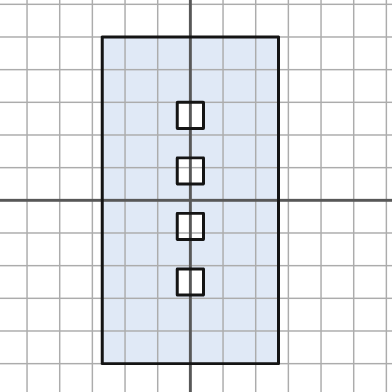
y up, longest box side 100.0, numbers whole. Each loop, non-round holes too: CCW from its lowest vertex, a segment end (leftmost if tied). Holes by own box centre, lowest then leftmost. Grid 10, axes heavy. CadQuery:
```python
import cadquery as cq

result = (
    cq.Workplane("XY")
    .moveTo(-27.0, -50.0)
    .lineTo(27.0, -50.0)
    .lineTo(27.0, 50.0)
    .lineTo(-27.0, 50.0)
    .close()
    .moveTo(-4.0, -29.0)
    .lineTo(4.0, -29.0)
    .lineTo(4.0, -21.0)
    .lineTo(-4.0, -21.0)
    .close()
    .moveTo(-4.0, -12.0)
    .lineTo(4.0, -12.0)
    .lineTo(4.0, -4.0)
    .lineTo(-4.0, -4.0)
    .close()
    .moveTo(-4.0, 5.0)
    .lineTo(4.0, 5.0)
    .lineTo(4.0, 13.0)
    .lineTo(-4.0, 13.0)
    .close()
    .moveTo(-4.0, 22.0)
    .lineTo(4.0, 22.0)
    .lineTo(4.0, 30.0)
    .lineTo(-4.0, 30.0)
    .close()
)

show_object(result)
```